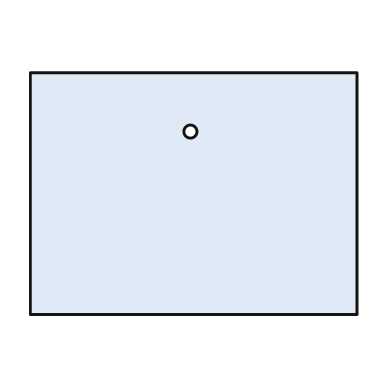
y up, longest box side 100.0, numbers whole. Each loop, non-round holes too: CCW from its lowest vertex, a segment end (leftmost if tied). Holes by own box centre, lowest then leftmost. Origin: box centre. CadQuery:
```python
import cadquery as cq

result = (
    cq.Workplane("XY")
    .moveTo(-50.0, -37.0)
    .lineTo(50.0, -37.0)
    .lineTo(50.0, 37.0)
    .lineTo(-50.0, 37.0)
    .close()
    .moveTo(-1.0, 19.0)
    .circle(2.0)
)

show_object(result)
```